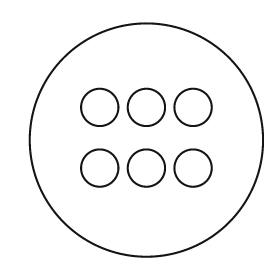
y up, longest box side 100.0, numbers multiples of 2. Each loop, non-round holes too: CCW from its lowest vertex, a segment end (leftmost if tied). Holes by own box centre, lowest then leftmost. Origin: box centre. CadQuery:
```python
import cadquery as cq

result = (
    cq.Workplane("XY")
    .moveTo(0.0, 0.0)
    .circle(50.0)
    .moveTo(-20.0, -12.0)
    .circle(8.0)
    .moveTo(0.0, -12.0)
    .circle(8.0)
    .moveTo(20.0, -12.0)
    .circle(8.0)
    .moveTo(-20.0, 14.0)
    .circle(8.0)
    .moveTo(0.0, 14.0)
    .circle(8.0)
    .moveTo(20.0, 14.0)
    .circle(8.0)
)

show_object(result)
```